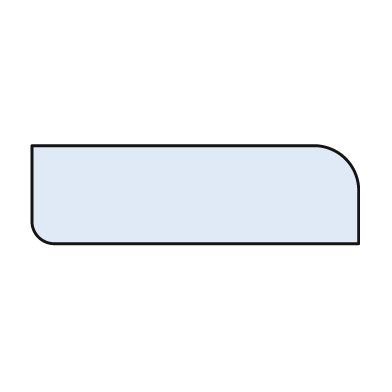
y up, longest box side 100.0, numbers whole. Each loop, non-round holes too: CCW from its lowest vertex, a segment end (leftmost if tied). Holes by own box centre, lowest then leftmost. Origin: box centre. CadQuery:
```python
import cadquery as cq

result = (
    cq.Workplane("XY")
    .moveTo(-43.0, -15.0)
    .lineTo(50.0, -15.0)
    .lineTo(50.0, 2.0)
    .threePointArc((46.0, 11.0), (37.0, 15.0))
    .lineTo(-50.0, 15.0)
    .lineTo(-50.0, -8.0)
    .threePointArc((-48.0, -13.0), (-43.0, -15.0))
    .close()
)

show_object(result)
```